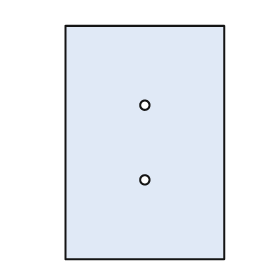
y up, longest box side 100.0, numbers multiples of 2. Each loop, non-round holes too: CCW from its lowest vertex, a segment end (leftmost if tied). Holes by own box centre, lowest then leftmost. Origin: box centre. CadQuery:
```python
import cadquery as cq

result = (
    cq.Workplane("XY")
    .moveTo(-34.0, -50.0)
    .lineTo(34.0, -50.0)
    .lineTo(34.0, 50.0)
    .lineTo(-34.0, 50.0)
    .close()
    .moveTo(0.0, -16.0)
    .circle(2.0)
    .moveTo(0.0, 16.0)
    .circle(2.0)
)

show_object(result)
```